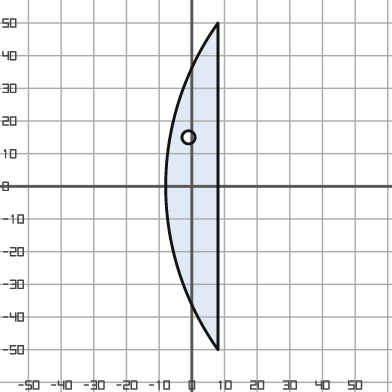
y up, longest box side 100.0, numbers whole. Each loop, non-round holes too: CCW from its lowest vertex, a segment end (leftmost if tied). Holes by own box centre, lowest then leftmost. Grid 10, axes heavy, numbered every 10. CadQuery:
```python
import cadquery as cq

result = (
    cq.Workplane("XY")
    .moveTo(8.0, -50.0)
    .lineTo(8.0, 50.0)
    .threePointArc((-8.0, 0.0), (8.0, -50.0))
    .close()
    .moveTo(-1.0, 15.0)
    .circle(2.0)
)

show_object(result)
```